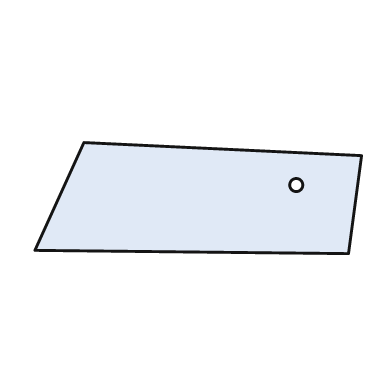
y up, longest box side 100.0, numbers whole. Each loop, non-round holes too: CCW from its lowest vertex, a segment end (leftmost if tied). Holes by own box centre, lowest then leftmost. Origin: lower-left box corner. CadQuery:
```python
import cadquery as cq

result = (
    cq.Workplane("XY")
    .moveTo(96.0, 0.0)
    .lineTo(100.0, 30.0)
    .lineTo(15.0, 34.0)
    .lineTo(0.0, 1.0)
    .close()
    .moveTo(80.0, 21.0)
    .circle(2.0)
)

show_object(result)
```